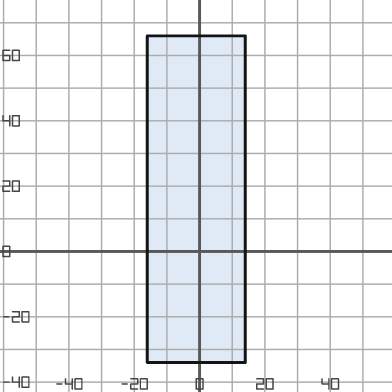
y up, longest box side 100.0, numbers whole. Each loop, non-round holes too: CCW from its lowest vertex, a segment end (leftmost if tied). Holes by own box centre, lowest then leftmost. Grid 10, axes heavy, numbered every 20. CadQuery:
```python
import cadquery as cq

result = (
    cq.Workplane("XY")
    .moveTo(-16.0, -34.0)
    .lineTo(14.0, -34.0)
    .lineTo(14.0, 66.0)
    .lineTo(-16.0, 66.0)
    .close()
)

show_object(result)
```